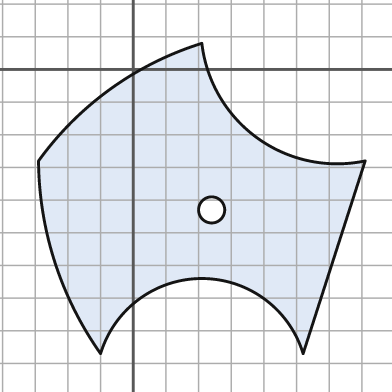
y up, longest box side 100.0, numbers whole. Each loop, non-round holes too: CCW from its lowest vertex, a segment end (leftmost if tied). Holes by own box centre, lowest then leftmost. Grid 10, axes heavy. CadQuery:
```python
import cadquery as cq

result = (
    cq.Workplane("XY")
    .moveTo(-10.0, -87.0)
    .threePointArc((21.0, -64.0), (52.0, -87.0))
    .lineTo(71.0, -28.0)
    .threePointArc((38.0, -21.0), (21.0, 8.0))
    .threePointArc((-7.0, -6.0), (-29.0, -28.0))
    .threePointArc((-24.0, -59.0), (-10.0, -87.0))
    .close()
    .moveTo(24.0, -43.0)
    .circle(4.0)
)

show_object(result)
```